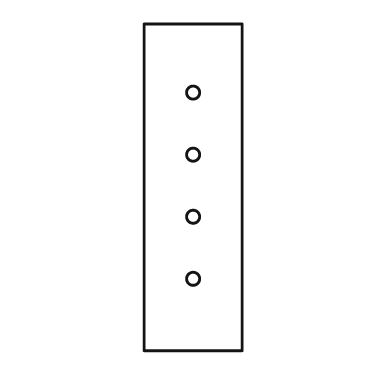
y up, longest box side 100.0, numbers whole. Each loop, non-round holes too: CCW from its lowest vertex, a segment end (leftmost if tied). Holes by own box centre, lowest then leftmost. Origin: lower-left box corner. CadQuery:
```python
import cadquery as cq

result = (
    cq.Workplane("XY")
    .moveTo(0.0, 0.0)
    .lineTo(30.0, 0.0)
    .lineTo(30.0, 100.0)
    .lineTo(0.0, 100.0)
    .close()
    .moveTo(15.0, 22.0)
    .circle(2.0)
    .moveTo(15.0, 41.0)
    .circle(2.0)
    .moveTo(15.0, 60.0)
    .circle(2.0)
    .moveTo(15.0, 79.0)
    .circle(2.0)
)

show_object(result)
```